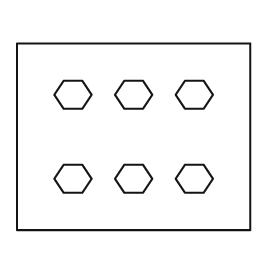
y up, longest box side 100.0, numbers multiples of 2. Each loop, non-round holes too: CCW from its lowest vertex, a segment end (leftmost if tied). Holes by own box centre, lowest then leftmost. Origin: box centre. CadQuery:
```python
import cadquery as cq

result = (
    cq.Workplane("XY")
    .moveTo(-50.0, -40.0)
    .lineTo(50.0, -40.0)
    .lineTo(50.0, 40.0)
    .lineTo(-50.0, 40.0)
    .close()
    .moveTo(-30.0, -24.0)
    .lineTo(-22.0, -24.0)
    .lineTo(-18.0, -18.0)
    .lineTo(-22.0, -12.0)
    .lineTo(-30.0, -12.0)
    .lineTo(-34.0, -18.0)
    .close()
    .moveTo(-4.0, -24.0)
    .lineTo(4.0, -24.0)
    .lineTo(8.0, -18.0)
    .lineTo(4.0, -12.0)
    .lineTo(-4.0, -12.0)
    .lineTo(-8.0, -18.0)
    .close()
    .moveTo(22.0, -24.0)
    .lineTo(30.0, -24.0)
    .lineTo(34.0, -18.0)
    .lineTo(30.0, -12.0)
    .lineTo(22.0, -12.0)
    .lineTo(18.0, -18.0)
    .close()
    .moveTo(-30.0, 12.0)
    .lineTo(-22.0, 12.0)
    .lineTo(-18.0, 18.0)
    .lineTo(-22.0, 24.0)
    .lineTo(-30.0, 24.0)
    .lineTo(-34.0, 18.0)
    .close()
    .moveTo(-4.0, 12.0)
    .lineTo(4.0, 12.0)
    .lineTo(8.0, 18.0)
    .lineTo(4.0, 24.0)
    .lineTo(-4.0, 24.0)
    .lineTo(-8.0, 18.0)
    .close()
    .moveTo(22.0, 12.0)
    .lineTo(30.0, 12.0)
    .lineTo(34.0, 18.0)
    .lineTo(30.0, 24.0)
    .lineTo(22.0, 24.0)
    .lineTo(18.0, 18.0)
    .close()
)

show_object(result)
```